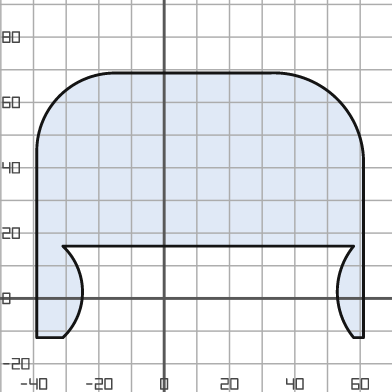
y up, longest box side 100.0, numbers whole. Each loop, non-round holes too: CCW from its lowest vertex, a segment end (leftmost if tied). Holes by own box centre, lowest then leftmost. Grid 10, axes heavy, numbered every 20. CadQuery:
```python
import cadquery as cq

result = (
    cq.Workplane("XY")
    .moveTo(-39.0, -12.0)
    .lineTo(-31.0, -12.0)
    .threePointArc((-25.0, 2.0), (-31.0, 16.0))
    .lineTo(58.0, 16.0)
    .threePointArc((53.0, 2.0), (58.0, -12.0))
    .lineTo(61.0, -12.0)
    .lineTo(61.0, 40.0)
    .threePointArc((53.0, 61.0), (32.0, 69.0))
    .lineTo(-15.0, 69.0)
    .threePointArc((-32.0, 62.0), (-39.0, 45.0))
    .close()
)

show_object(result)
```